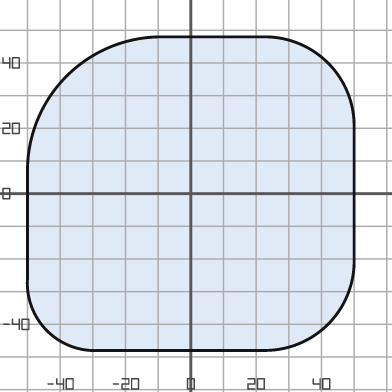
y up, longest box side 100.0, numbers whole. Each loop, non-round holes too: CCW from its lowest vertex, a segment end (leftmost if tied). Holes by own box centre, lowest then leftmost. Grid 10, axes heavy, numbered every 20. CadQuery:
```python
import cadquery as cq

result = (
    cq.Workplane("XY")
    .moveTo(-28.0, -48.0)
    .lineTo(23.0, -48.0)
    .threePointArc((42.0, -40.0), (50.0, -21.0))
    .lineTo(50.0, 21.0)
    .threePointArc((42.0, 40.0), (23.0, 48.0))
    .lineTo(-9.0, 48.0)
    .threePointArc((-38.0, 36.0), (-50.0, 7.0))
    .lineTo(-50.0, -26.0)
    .threePointArc((-44.0, -42.0), (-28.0, -48.0))
    .close()
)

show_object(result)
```